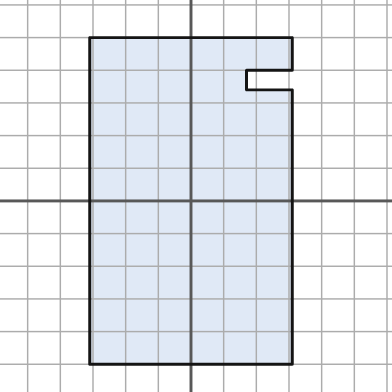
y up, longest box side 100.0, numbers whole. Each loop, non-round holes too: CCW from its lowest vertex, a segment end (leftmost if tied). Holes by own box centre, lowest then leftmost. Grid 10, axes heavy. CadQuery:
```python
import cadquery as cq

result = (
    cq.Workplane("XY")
    .moveTo(-31.0, -50.0)
    .lineTo(31.0, -50.0)
    .lineTo(31.0, 34.0)
    .lineTo(17.0, 34.0)
    .lineTo(17.0, 40.0)
    .lineTo(31.0, 40.0)
    .lineTo(31.0, 50.0)
    .lineTo(-31.0, 50.0)
    .close()
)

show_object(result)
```